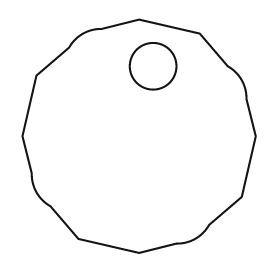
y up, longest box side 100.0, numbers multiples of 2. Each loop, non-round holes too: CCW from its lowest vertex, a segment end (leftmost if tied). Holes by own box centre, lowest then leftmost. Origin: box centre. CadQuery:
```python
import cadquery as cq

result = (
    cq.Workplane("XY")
    .moveTo(0.0, -50.0)
    .lineTo(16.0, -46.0)
    .threePointArc((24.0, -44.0), (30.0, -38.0))
    .lineTo(44.0, -26.0)
    .lineTo(50.0, 0.0)
    .lineTo(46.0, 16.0)
    .threePointArc((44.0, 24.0), (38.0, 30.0))
    .lineTo(26.0, 44.0)
    .lineTo(0.0, 50.0)
    .lineTo(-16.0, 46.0)
    .threePointArc((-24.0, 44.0), (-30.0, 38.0))
    .lineTo(-44.0, 26.0)
    .lineTo(-50.0, 0.0)
    .lineTo(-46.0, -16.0)
    .threePointArc((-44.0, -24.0), (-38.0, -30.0))
    .lineTo(-26.0, -44.0)
    .close()
    .moveTo(6.0, 30.0)
    .circle(10.0)
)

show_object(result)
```